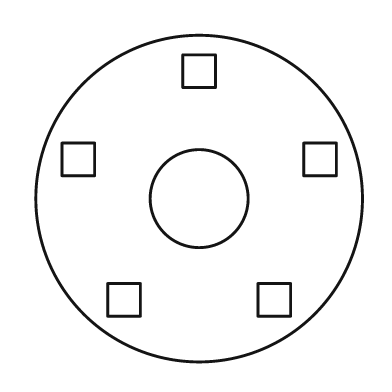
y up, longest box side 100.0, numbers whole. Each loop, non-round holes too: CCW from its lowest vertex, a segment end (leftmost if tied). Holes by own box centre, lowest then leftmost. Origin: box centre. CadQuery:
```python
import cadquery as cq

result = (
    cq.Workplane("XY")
    .moveTo(0.0, 0.0)
    .circle(50.0)
    .moveTo(-28.0, -36.0)
    .lineTo(-18.0, -36.0)
    .lineTo(-18.0, -26.0)
    .lineTo(-28.0, -26.0)
    .close()
    .moveTo(18.0, -36.0)
    .lineTo(28.0, -36.0)
    .lineTo(28.0, -26.0)
    .lineTo(18.0, -26.0)
    .close()
    .moveTo(0.0, 0.0)
    .circle(15.0)
    .moveTo(-42.0, 7.0)
    .lineTo(-32.0, 7.0)
    .lineTo(-32.0, 17.0)
    .lineTo(-42.0, 17.0)
    .close()
    .moveTo(32.0, 7.0)
    .lineTo(42.0, 7.0)
    .lineTo(42.0, 17.0)
    .lineTo(32.0, 17.0)
    .close()
    .moveTo(-5.0, 34.0)
    .lineTo(5.0, 34.0)
    .lineTo(5.0, 44.0)
    .lineTo(-5.0, 44.0)
    .close()
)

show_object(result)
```